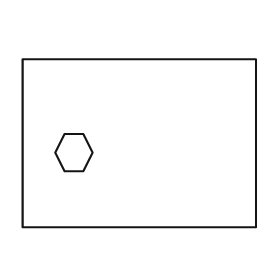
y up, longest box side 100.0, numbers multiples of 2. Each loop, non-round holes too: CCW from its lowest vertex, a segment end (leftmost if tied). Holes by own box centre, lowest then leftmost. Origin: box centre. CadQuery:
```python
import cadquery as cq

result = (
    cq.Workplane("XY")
    .moveTo(-50.0, -36.0)
    .lineTo(50.0, -36.0)
    .lineTo(50.0, 36.0)
    .lineTo(-50.0, 36.0)
    .close()
    .moveTo(-32.0, -12.0)
    .lineTo(-24.0, -12.0)
    .lineTo(-20.0, -4.0)
    .lineTo(-24.0, 4.0)
    .lineTo(-32.0, 4.0)
    .lineTo(-36.0, -4.0)
    .close()
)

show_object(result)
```